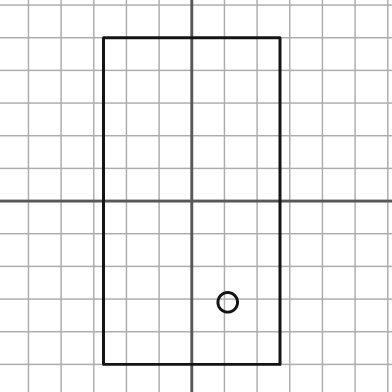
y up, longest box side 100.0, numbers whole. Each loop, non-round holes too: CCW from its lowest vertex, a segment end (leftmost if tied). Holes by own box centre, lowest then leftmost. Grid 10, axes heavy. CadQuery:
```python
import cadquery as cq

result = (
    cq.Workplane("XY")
    .moveTo(-27.0, -50.0)
    .lineTo(27.0, -50.0)
    .lineTo(27.0, 50.0)
    .lineTo(-27.0, 50.0)
    .close()
    .moveTo(11.0, -31.0)
    .circle(3.0)
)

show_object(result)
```